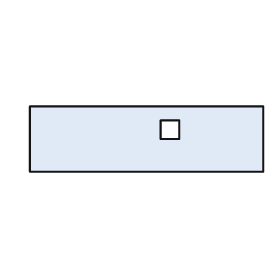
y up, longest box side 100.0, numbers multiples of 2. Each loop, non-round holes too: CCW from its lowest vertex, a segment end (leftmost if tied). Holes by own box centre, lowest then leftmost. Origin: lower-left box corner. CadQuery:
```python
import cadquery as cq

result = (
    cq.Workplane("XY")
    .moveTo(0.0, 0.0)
    .lineTo(100.0, 0.0)
    .lineTo(100.0, 28.0)
    .lineTo(0.0, 28.0)
    .close()
    .moveTo(56.0, 14.0)
    .lineTo(64.0, 14.0)
    .lineTo(64.0, 22.0)
    .lineTo(56.0, 22.0)
    .close()
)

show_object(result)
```